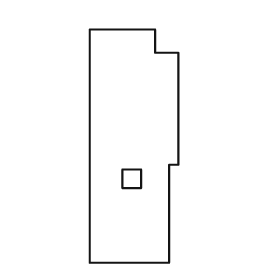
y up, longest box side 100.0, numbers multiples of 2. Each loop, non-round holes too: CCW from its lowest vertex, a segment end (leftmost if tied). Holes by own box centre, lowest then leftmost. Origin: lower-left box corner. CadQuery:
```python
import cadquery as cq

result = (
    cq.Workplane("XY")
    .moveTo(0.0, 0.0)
    .lineTo(34.0, 0.0)
    .lineTo(34.0, 42.0)
    .lineTo(38.0, 42.0)
    .lineTo(38.0, 90.0)
    .lineTo(28.0, 90.0)
    .lineTo(28.0, 100.0)
    .lineTo(0.0, 100.0)
    .close()
    .moveTo(14.0, 32.0)
    .lineTo(22.0, 32.0)
    .lineTo(22.0, 40.0)
    .lineTo(14.0, 40.0)
    .close()
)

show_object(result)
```